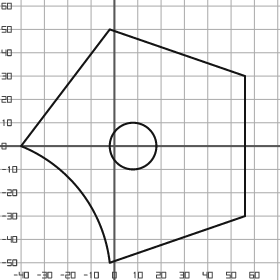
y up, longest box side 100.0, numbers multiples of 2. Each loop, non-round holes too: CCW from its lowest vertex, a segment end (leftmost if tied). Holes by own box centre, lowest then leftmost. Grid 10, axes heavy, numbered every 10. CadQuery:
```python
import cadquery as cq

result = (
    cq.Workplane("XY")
    .moveTo(-2.0, -50.0)
    .lineTo(56.0, -30.0)
    .lineTo(56.0, 30.0)
    .lineTo(-2.0, 50.0)
    .lineTo(-40.0, 0.0)
    .threePointArc((-14.0, -20.0), (-2.0, -50.0))
    .close()
    .moveTo(8.0, 0.0)
    .circle(10.0)
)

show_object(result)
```